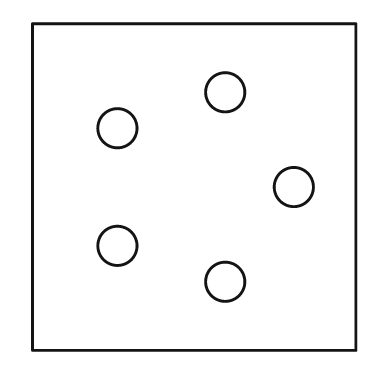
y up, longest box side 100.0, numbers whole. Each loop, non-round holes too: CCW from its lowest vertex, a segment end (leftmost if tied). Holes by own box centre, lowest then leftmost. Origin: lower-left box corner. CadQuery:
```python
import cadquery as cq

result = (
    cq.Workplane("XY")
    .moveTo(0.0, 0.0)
    .lineTo(99.0, 0.0)
    .lineTo(99.0, 100.0)
    .lineTo(0.0, 100.0)
    .close()
    .moveTo(59.0, 21.0)
    .circle(6.0)
    .moveTo(26.0, 32.0)
    .circle(6.0)
    .moveTo(80.0, 50.0)
    .circle(6.0)
    .moveTo(26.0, 68.0)
    .circle(6.0)
    .moveTo(59.0, 79.0)
    .circle(6.0)
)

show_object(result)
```